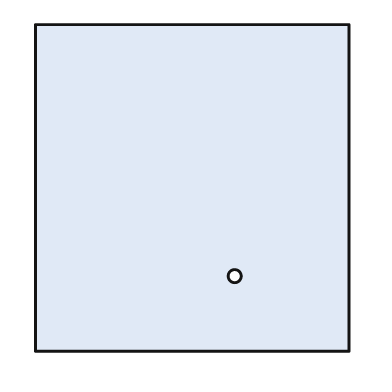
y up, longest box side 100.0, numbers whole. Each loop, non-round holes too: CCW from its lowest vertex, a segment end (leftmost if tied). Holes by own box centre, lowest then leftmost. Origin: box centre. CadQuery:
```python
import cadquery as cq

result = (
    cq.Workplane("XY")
    .moveTo(-48.0, -50.0)
    .lineTo(48.0, -50.0)
    .lineTo(48.0, 50.0)
    .lineTo(-48.0, 50.0)
    .close()
    .moveTo(13.0, -27.0)
    .circle(2.0)
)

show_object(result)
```